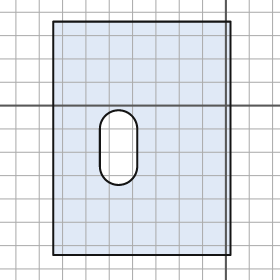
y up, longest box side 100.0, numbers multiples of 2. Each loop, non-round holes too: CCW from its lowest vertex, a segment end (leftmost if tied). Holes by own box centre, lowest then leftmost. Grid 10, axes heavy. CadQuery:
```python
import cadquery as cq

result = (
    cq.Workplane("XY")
    .moveTo(-74.0, -64.0)
    .lineTo(2.0, -64.0)
    .lineTo(2.0, 36.0)
    .lineTo(-74.0, 36.0)
    .close()
    .moveTo(-54.0, -26.0)
    .threePointArc((-46.0, -34.0), (-38.0, -26.0))
    .lineTo(-38.0, -10.0)
    .threePointArc((-46.0, -2.0), (-54.0, -10.0))
    .close()
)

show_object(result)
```